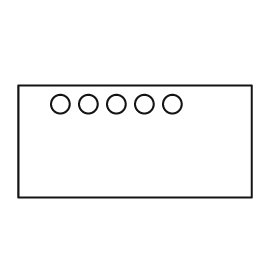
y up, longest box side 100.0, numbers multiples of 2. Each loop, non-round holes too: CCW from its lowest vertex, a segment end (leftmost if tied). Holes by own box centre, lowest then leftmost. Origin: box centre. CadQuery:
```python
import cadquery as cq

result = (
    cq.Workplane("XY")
    .moveTo(-50.0, -24.0)
    .lineTo(50.0, -24.0)
    .lineTo(50.0, 24.0)
    .lineTo(-50.0, 24.0)
    .close()
    .moveTo(-32.0, 16.0)
    .circle(4.0)
    .moveTo(-20.0, 16.0)
    .circle(4.0)
    .moveTo(-8.0, 16.0)
    .circle(4.0)
    .moveTo(4.0, 16.0)
    .circle(4.0)
    .moveTo(16.0, 16.0)
    .circle(4.0)
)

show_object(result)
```